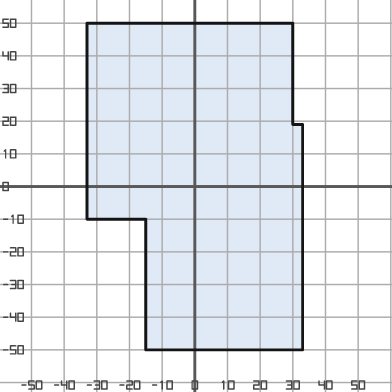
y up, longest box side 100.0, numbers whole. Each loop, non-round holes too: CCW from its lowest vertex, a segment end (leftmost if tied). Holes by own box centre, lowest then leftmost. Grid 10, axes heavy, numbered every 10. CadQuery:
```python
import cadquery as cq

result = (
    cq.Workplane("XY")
    .moveTo(-15.0, -50.0)
    .lineTo(33.0, -50.0)
    .lineTo(33.0, 19.0)
    .lineTo(30.0, 19.0)
    .lineTo(30.0, 50.0)
    .lineTo(-33.0, 50.0)
    .lineTo(-33.0, -10.0)
    .lineTo(-15.0, -10.0)
    .close()
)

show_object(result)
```